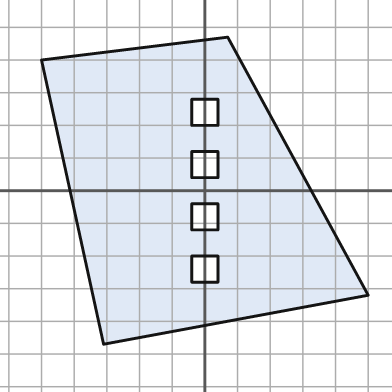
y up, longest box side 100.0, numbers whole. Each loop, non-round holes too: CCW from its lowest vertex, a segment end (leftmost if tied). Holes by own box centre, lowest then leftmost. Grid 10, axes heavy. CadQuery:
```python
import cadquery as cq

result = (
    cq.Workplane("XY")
    .moveTo(-31.0, -47.0)
    .lineTo(50.0, -32.0)
    .lineTo(7.0, 47.0)
    .lineTo(-50.0, 40.0)
    .close()
    .moveTo(-4.0, -28.0)
    .lineTo(4.0, -28.0)
    .lineTo(4.0, -20.0)
    .lineTo(-4.0, -20.0)
    .close()
    .moveTo(-4.0, -12.0)
    .lineTo(4.0, -12.0)
    .lineTo(4.0, -4.0)
    .lineTo(-4.0, -4.0)
    .close()
    .moveTo(-4.0, 4.0)
    .lineTo(4.0, 4.0)
    .lineTo(4.0, 12.0)
    .lineTo(-4.0, 12.0)
    .close()
    .moveTo(-4.0, 20.0)
    .lineTo(4.0, 20.0)
    .lineTo(4.0, 28.0)
    .lineTo(-4.0, 28.0)
    .close()
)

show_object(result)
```